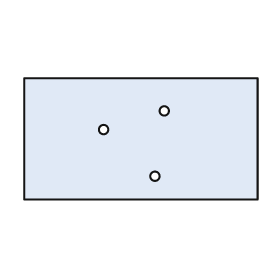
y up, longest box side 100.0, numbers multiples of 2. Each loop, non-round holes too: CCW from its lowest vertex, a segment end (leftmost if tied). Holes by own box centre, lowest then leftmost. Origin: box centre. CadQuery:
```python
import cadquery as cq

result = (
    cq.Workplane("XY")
    .moveTo(-50.0, -26.0)
    .lineTo(50.0, -26.0)
    .lineTo(50.0, 26.0)
    .lineTo(-50.0, 26.0)
    .close()
    .moveTo(6.0, -16.0)
    .circle(2.0)
    .moveTo(-16.0, 4.0)
    .circle(2.0)
    .moveTo(10.0, 12.0)
    .circle(2.0)
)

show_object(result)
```